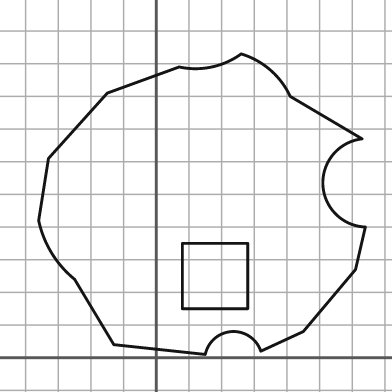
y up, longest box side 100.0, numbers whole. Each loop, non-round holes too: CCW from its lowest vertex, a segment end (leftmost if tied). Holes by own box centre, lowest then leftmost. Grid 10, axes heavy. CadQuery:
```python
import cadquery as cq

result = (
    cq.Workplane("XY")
    .moveTo(15.0, 1.0)
    .threePointArc((23.0, 8.0), (32.0, 2.0))
    .lineTo(45.0, 8.0)
    .lineTo(61.0, 27.0)
    .lineTo(64.0, 40.0)
    .threePointArc((51.0, 53.0), (63.0, 67.0))
    .lineTo(41.0, 80.0)
    .threePointArc((35.0, 88.0), (26.0, 93.0))
    .threePointArc((17.0, 89.0), (7.0, 89.0))
    .lineTo(-15.0, 81.0)
    .lineTo(-33.0, 61.0)
    .lineTo(-36.0, 42.0)
    .threePointArc((-32.0, 32.0), (-25.0, 24.0))
    .lineTo(-13.0, 4.0)
    .close()
    .moveTo(8.0, 15.0)
    .lineTo(28.0, 15.0)
    .lineTo(28.0, 35.0)
    .lineTo(8.0, 35.0)
    .close()
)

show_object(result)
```